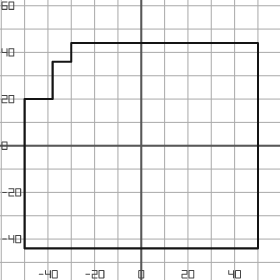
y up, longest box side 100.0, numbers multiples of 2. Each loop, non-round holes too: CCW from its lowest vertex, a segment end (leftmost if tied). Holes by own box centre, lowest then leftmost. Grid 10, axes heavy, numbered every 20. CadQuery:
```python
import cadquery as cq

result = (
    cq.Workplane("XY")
    .moveTo(-50.0, -44.0)
    .lineTo(50.0, -44.0)
    .lineTo(50.0, 44.0)
    .lineTo(-30.0, 44.0)
    .lineTo(-30.0, 36.0)
    .lineTo(-38.0, 36.0)
    .lineTo(-38.0, 20.0)
    .lineTo(-50.0, 20.0)
    .close()
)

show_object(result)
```